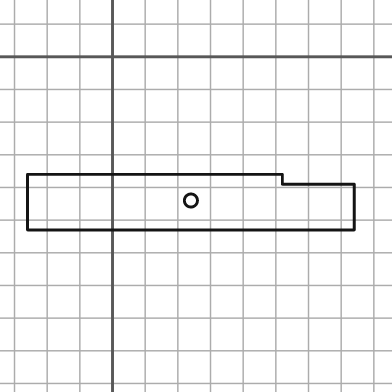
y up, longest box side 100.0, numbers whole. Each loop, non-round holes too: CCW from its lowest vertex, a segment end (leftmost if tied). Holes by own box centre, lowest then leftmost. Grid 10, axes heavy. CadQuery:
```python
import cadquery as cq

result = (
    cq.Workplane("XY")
    .moveTo(-26.0, -53.0)
    .lineTo(74.0, -53.0)
    .lineTo(74.0, -39.0)
    .lineTo(52.0, -39.0)
    .lineTo(52.0, -36.0)
    .lineTo(-26.0, -36.0)
    .close()
    .moveTo(24.0, -44.0)
    .circle(2.0)
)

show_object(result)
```